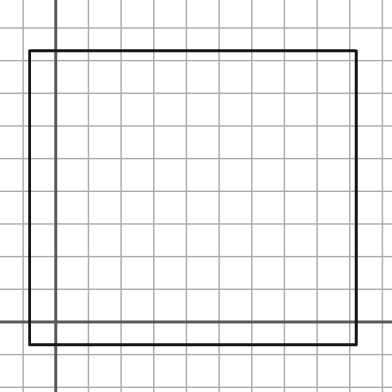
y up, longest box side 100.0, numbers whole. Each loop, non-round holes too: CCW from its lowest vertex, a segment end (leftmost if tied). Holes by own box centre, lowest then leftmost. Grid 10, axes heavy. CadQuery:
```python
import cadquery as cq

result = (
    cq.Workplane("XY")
    .moveTo(-8.0, -7.0)
    .lineTo(92.0, -7.0)
    .lineTo(92.0, 83.0)
    .lineTo(-8.0, 83.0)
    .close()
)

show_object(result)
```